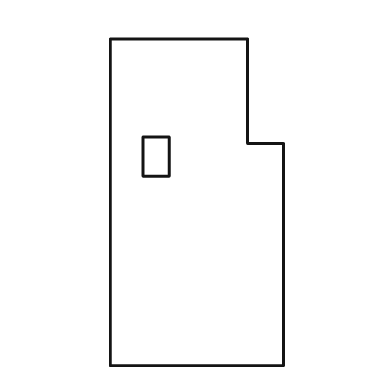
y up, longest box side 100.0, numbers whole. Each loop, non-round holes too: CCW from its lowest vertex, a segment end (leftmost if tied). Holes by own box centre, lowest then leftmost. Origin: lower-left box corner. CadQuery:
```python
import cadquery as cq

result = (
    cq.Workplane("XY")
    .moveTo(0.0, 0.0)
    .lineTo(53.0, 0.0)
    .lineTo(53.0, 68.0)
    .lineTo(42.0, 68.0)
    .lineTo(42.0, 100.0)
    .lineTo(0.0, 100.0)
    .close()
    .moveTo(10.0, 58.0)
    .lineTo(18.0, 58.0)
    .lineTo(18.0, 70.0)
    .lineTo(10.0, 70.0)
    .close()
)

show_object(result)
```